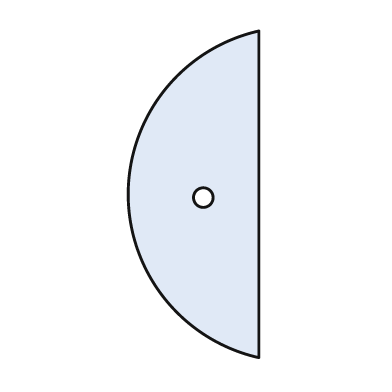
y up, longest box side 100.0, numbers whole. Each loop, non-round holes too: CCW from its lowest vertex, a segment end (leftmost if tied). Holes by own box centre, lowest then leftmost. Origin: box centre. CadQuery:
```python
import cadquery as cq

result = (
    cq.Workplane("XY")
    .moveTo(20.0, -50.0)
    .lineTo(20.0, 50.0)
    .threePointArc((-20.0, 0.0), (20.0, -50.0))
    .close()
    .moveTo(3.0, -1.0)
    .circle(3.0)
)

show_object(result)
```